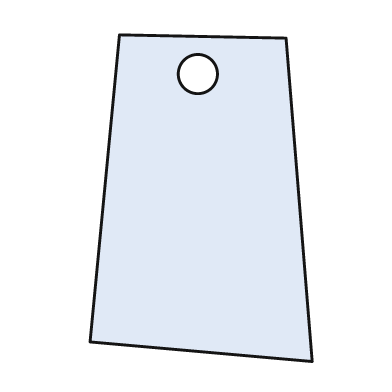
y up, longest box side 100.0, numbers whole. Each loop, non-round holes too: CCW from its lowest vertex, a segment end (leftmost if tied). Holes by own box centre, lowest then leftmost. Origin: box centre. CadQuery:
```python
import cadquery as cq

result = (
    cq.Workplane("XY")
    .moveTo(34.0, -50.0)
    .lineTo(26.0, 49.0)
    .lineTo(-25.0, 50.0)
    .lineTo(-34.0, -44.0)
    .close()
    .moveTo(-1.0, 38.0)
    .circle(6.0)
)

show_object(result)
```